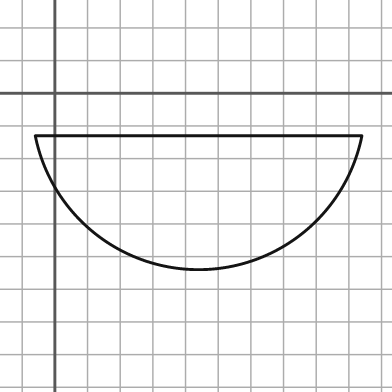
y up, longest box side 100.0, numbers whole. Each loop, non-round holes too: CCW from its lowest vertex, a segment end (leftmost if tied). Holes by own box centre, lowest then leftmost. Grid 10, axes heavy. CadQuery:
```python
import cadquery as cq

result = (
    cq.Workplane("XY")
    .moveTo(-6.0, -13.0)
    .threePointArc((44.0, -54.0), (94.0, -13.0))
    .close()
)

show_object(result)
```